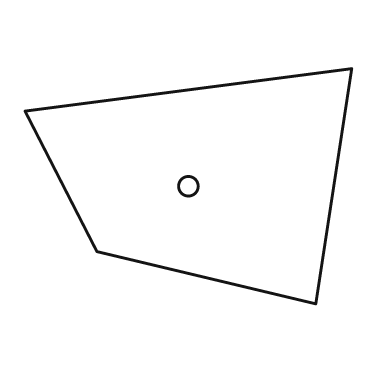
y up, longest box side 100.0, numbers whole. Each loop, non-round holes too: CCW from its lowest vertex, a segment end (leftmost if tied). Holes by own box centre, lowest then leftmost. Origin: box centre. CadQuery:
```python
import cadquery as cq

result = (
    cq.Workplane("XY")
    .moveTo(39.0, -36.0)
    .lineTo(50.0, 36.0)
    .lineTo(-50.0, 23.0)
    .lineTo(-28.0, -20.0)
    .close()
    .moveTo(0.0, 0.0)
    .circle(3.0)
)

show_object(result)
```